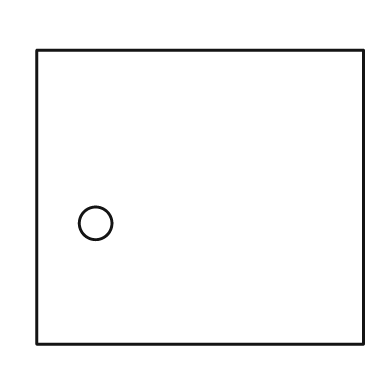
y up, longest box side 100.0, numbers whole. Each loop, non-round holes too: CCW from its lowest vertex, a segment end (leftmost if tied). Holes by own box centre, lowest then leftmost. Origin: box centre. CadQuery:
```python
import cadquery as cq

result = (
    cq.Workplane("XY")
    .moveTo(-50.0, -45.0)
    .lineTo(50.0, -45.0)
    .lineTo(50.0, 45.0)
    .lineTo(-50.0, 45.0)
    .close()
    .moveTo(-32.0, -8.0)
    .circle(5.0)
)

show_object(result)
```